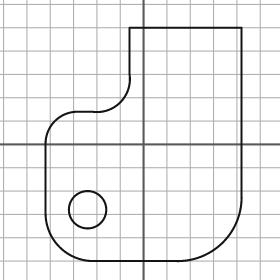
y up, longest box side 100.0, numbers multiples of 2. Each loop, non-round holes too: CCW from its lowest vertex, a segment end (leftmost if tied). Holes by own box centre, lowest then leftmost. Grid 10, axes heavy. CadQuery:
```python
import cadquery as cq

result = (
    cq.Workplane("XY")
    .moveTo(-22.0, -50.0)
    .lineTo(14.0, -50.0)
    .threePointArc((34.0, -42.0), (42.0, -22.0))
    .lineTo(42.0, 50.0)
    .lineTo(-6.0, 50.0)
    .lineTo(-6.0, 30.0)
    .threePointArc((-10.0, 18.0), (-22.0, 14.0))
    .lineTo(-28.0, 14.0)
    .threePointArc((-38.0, 10.0), (-42.0, 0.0))
    .lineTo(-42.0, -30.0)
    .threePointArc((-36.0, -44.0), (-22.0, -50.0))
    .close()
    .moveTo(-24.0, -28.0)
    .circle(8.0)
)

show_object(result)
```